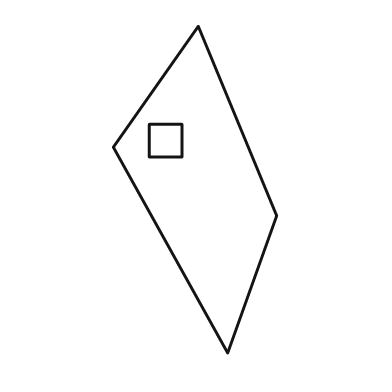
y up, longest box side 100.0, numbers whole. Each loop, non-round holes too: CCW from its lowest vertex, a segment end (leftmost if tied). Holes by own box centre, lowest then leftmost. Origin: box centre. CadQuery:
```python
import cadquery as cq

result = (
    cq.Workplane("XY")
    .moveTo(10.0, -50.0)
    .lineTo(25.0, -8.0)
    .lineTo(1.0, 50.0)
    .lineTo(-25.0, 13.0)
    .close()
    .moveTo(-14.0, 10.0)
    .lineTo(-4.0, 10.0)
    .lineTo(-4.0, 20.0)
    .lineTo(-14.0, 20.0)
    .close()
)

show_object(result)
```